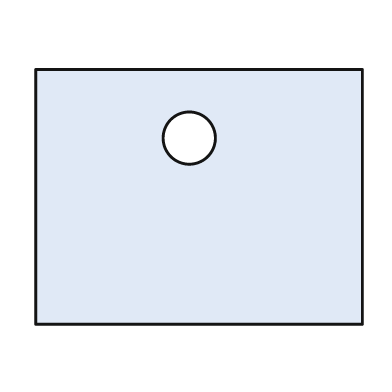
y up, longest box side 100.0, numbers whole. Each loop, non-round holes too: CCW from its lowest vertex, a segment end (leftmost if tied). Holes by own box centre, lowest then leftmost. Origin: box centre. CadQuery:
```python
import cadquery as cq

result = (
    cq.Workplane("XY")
    .moveTo(-50.0, -39.0)
    .lineTo(50.0, -39.0)
    .lineTo(50.0, 39.0)
    .lineTo(-50.0, 39.0)
    .close()
    .moveTo(-3.0, 18.0)
    .circle(8.0)
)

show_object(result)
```